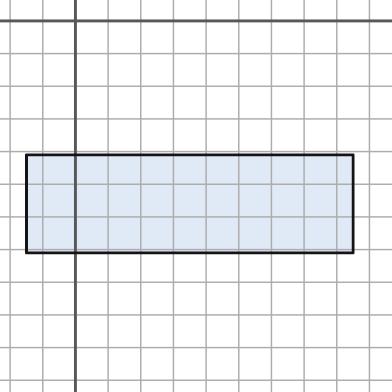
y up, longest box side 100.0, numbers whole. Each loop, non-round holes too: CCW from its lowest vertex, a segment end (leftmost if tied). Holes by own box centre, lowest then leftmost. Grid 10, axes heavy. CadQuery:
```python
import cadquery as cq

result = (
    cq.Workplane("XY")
    .moveTo(-15.0, -71.0)
    .lineTo(85.0, -71.0)
    .lineTo(85.0, -41.0)
    .lineTo(-15.0, -41.0)
    .close()
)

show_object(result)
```